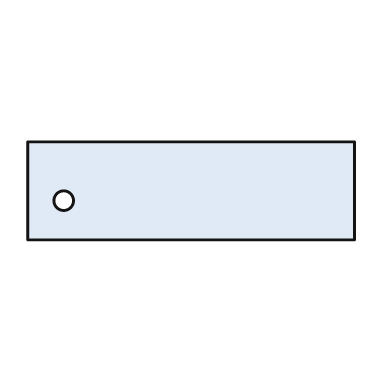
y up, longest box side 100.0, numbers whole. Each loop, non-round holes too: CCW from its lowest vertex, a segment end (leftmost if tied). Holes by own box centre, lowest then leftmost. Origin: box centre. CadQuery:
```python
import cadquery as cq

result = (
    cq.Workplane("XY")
    .moveTo(-50.0, -15.0)
    .lineTo(50.0, -15.0)
    .lineTo(50.0, 15.0)
    .lineTo(-50.0, 15.0)
    .close()
    .moveTo(-39.0, -3.0)
    .circle(3.0)
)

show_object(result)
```